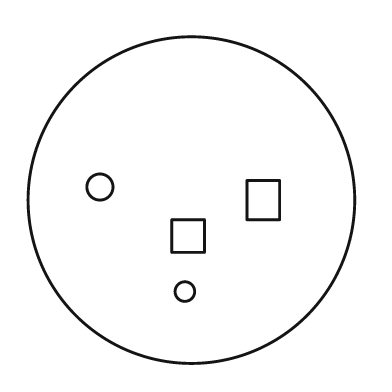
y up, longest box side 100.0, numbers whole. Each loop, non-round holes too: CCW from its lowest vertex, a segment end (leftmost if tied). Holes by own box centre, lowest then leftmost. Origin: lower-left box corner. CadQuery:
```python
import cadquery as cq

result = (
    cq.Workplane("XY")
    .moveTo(50.0, 50.0)
    .circle(50.0)
    .moveTo(48.0, 22.0)
    .circle(3.0)
    .moveTo(44.0, 34.0)
    .lineTo(54.0, 34.0)
    .lineTo(54.0, 44.0)
    .lineTo(44.0, 44.0)
    .close()
    .moveTo(67.0, 44.0)
    .lineTo(77.0, 44.0)
    .lineTo(77.0, 56.0)
    .lineTo(67.0, 56.0)
    .close()
    .moveTo(22.0, 54.0)
    .circle(4.0)
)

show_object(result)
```